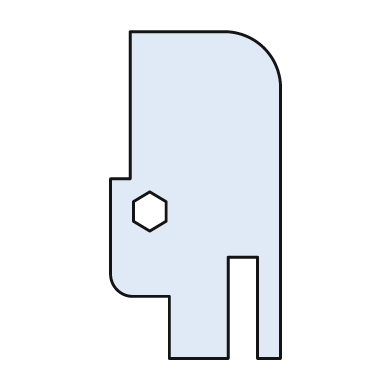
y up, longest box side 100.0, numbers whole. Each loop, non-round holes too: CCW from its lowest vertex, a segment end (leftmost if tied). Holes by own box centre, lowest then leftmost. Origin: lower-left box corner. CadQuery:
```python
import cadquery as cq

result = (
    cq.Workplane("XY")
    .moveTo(18.0, 0.0)
    .lineTo(36.0, 0.0)
    .lineTo(36.0, 31.0)
    .lineTo(45.0, 31.0)
    .lineTo(45.0, 0.0)
    .lineTo(52.0, 0.0)
    .lineTo(52.0, 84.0)
    .threePointArc((47.0, 95.0), (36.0, 100.0))
    .lineTo(6.0, 100.0)
    .lineTo(6.0, 55.0)
    .lineTo(0.0, 55.0)
    .lineTo(0.0, 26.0)
    .threePointArc((2.0, 21.0), (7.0, 19.0))
    .lineTo(18.0, 19.0)
    .close()
    .moveTo(12.0, 39.0)
    .lineTo(17.0, 42.0)
    .lineTo(17.0, 48.0)
    .lineTo(12.0, 51.0)
    .lineTo(7.0, 48.0)
    .lineTo(7.0, 42.0)
    .close()
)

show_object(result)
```